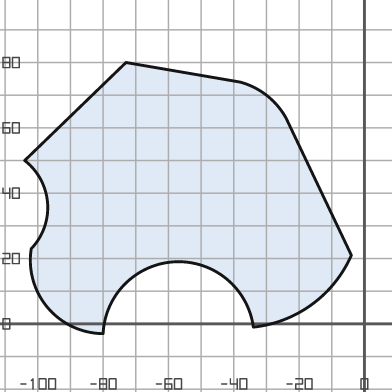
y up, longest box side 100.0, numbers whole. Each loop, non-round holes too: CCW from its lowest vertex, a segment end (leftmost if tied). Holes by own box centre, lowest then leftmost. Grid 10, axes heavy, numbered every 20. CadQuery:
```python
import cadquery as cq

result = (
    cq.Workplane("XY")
    .moveTo(-80.0, -3.0)
    .threePointArc((-58.0, 19.0), (-34.0, -1.0))
    .threePointArc((-16.0, 6.0), (-4.0, 21.0))
    .lineTo(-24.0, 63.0)
    .threePointArc((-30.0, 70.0), (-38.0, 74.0))
    .lineTo(-73.0, 80.0)
    .lineTo(-104.0, 50.0)
    .threePointArc((-97.0, 37.0), (-102.0, 23.0))
    .threePointArc((-97.0, 5.0), (-80.0, -3.0))
    .close()
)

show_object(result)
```